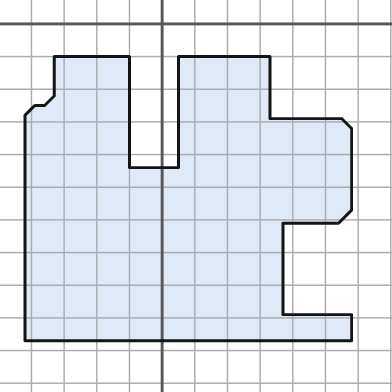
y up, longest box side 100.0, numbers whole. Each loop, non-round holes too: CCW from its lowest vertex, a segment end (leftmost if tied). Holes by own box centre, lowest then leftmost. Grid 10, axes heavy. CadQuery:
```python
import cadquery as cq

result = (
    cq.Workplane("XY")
    .moveTo(-42.0, -97.0)
    .lineTo(58.0, -97.0)
    .lineTo(58.0, -89.0)
    .lineTo(37.0, -89.0)
    .lineTo(37.0, -61.0)
    .lineTo(54.0, -61.0)
    .lineTo(58.0, -57.0)
    .lineTo(58.0, -32.0)
    .lineTo(55.0, -29.0)
    .lineTo(33.0, -29.0)
    .lineTo(33.0, -10.0)
    .lineTo(5.0, -10.0)
    .lineTo(5.0, -44.0)
    .lineTo(-10.0, -44.0)
    .lineTo(-10.0, -10.0)
    .lineTo(-33.0, -10.0)
    .lineTo(-33.0, -22.0)
    .lineTo(-36.0, -25.0)
    .lineTo(-39.0, -25.0)
    .lineTo(-42.0, -28.0)
    .close()
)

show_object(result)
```